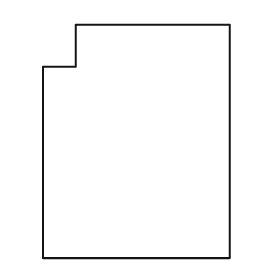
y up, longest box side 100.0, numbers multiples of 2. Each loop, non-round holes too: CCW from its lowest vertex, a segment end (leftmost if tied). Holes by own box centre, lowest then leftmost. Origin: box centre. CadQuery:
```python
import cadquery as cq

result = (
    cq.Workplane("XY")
    .moveTo(-40.0, -50.0)
    .lineTo(40.0, -50.0)
    .lineTo(40.0, 50.0)
    .lineTo(-26.0, 50.0)
    .lineTo(-26.0, 32.0)
    .lineTo(-40.0, 32.0)
    .close()
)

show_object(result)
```